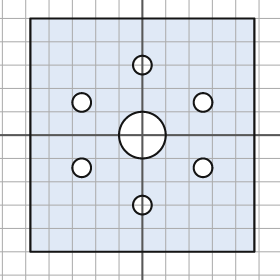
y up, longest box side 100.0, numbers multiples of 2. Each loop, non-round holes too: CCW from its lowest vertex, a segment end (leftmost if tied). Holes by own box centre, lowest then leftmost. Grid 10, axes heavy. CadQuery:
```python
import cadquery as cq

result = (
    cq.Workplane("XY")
    .moveTo(-48.0, -50.0)
    .lineTo(48.0, -50.0)
    .lineTo(48.0, 50.0)
    .lineTo(-48.0, 50.0)
    .close()
    .moveTo(0.0, -30.0)
    .circle(4.0)
    .moveTo(-26.0, -14.0)
    .circle(4.0)
    .moveTo(26.0, -14.0)
    .circle(4.0)
    .moveTo(0.0, 0.0)
    .circle(10.0)
    .moveTo(-26.0, 14.0)
    .circle(4.0)
    .moveTo(26.0, 14.0)
    .circle(4.0)
    .moveTo(0.0, 30.0)
    .circle(4.0)
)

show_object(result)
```